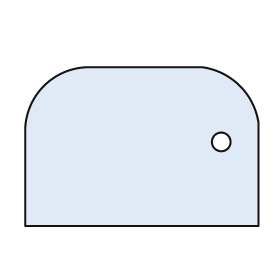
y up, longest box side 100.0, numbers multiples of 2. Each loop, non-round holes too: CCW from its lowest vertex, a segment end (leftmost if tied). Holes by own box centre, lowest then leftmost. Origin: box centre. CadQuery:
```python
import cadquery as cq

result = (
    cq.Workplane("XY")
    .moveTo(-50.0, -34.0)
    .lineTo(50.0, -34.0)
    .lineTo(50.0, 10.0)
    .threePointArc((42.0, 26.0), (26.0, 34.0))
    .lineTo(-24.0, 34.0)
    .threePointArc((-42.0, 26.0), (-50.0, 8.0))
    .close()
    .moveTo(34.0, 2.0)
    .circle(4.0)
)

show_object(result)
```